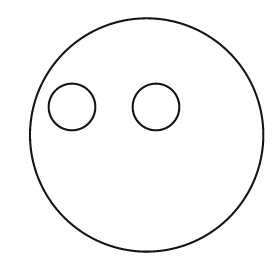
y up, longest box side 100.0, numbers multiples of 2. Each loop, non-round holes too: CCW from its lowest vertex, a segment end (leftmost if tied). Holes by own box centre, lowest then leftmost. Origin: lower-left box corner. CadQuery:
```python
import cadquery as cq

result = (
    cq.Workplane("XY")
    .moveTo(50.0, 50.0)
    .circle(50.0)
    .moveTo(18.0, 62.0)
    .circle(10.0)
    .moveTo(54.0, 62.0)
    .circle(10.0)
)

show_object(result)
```